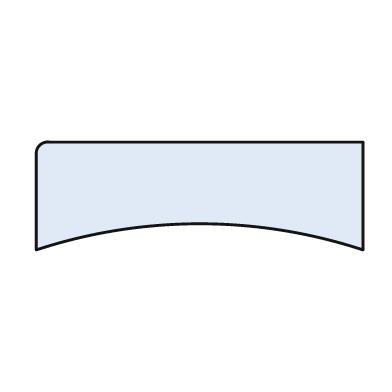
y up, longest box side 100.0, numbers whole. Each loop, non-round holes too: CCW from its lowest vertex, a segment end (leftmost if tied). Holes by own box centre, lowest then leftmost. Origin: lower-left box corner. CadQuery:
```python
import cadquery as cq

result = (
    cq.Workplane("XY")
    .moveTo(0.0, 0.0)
    .threePointArc((50.0, 8.0), (100.0, 0.0))
    .lineTo(100.0, 33.0)
    .lineTo(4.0, 33.0)
    .threePointArc((1.0, 32.0), (0.0, 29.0))
    .close()
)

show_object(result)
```